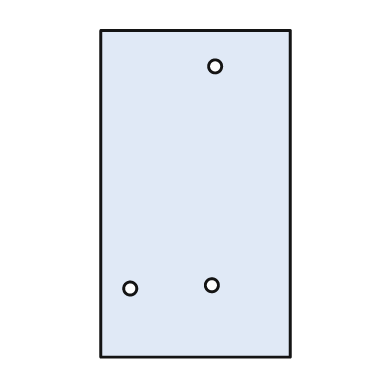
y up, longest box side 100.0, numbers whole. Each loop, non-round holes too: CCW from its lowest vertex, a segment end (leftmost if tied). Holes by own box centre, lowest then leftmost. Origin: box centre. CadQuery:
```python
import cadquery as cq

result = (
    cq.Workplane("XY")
    .moveTo(-29.0, -50.0)
    .lineTo(29.0, -50.0)
    .lineTo(29.0, 50.0)
    .lineTo(-29.0, 50.0)
    .close()
    .moveTo(-20.0, -29.0)
    .circle(2.0)
    .moveTo(5.0, -28.0)
    .circle(2.0)
    .moveTo(6.0, 39.0)
    .circle(2.0)
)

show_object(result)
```